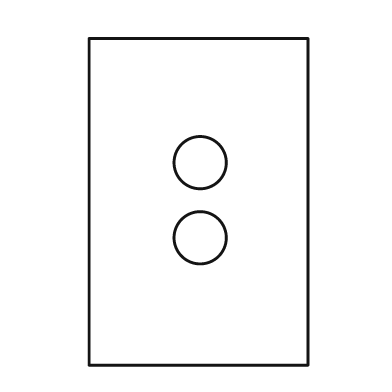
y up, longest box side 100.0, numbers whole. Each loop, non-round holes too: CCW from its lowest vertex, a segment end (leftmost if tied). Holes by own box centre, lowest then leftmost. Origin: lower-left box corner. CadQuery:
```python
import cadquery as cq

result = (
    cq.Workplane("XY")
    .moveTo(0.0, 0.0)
    .lineTo(67.0, 0.0)
    .lineTo(67.0, 100.0)
    .lineTo(0.0, 100.0)
    .close()
    .moveTo(34.0, 39.0)
    .circle(8.0)
    .moveTo(34.0, 62.0)
    .circle(8.0)
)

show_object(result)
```